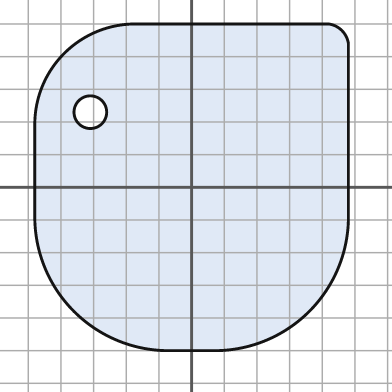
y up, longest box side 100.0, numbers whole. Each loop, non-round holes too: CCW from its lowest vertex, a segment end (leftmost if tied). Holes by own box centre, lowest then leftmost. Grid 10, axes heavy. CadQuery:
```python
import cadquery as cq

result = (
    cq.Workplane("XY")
    .moveTo(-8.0, -50.0)
    .lineTo(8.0, -50.0)
    .threePointArc((36.0, -38.0), (48.0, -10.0))
    .lineTo(48.0, 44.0)
    .threePointArc((46.0, 48.0), (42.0, 50.0))
    .lineTo(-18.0, 50.0)
    .threePointArc((-39.0, 41.0), (-48.0, 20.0))
    .lineTo(-48.0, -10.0)
    .threePointArc((-36.0, -38.0), (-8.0, -50.0))
    .close()
    .moveTo(-31.0, 23.0)
    .circle(5.0)
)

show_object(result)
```